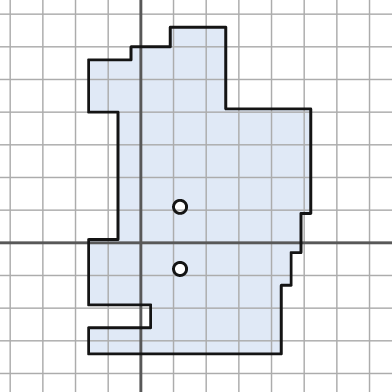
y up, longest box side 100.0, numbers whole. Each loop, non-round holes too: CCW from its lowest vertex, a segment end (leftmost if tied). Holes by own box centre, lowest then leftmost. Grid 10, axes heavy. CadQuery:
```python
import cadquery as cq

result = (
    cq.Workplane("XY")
    .moveTo(-16.0, -34.0)
    .lineTo(43.0, -34.0)
    .lineTo(43.0, -13.0)
    .lineTo(46.0, -13.0)
    .lineTo(46.0, -3.0)
    .lineTo(49.0, -3.0)
    .lineTo(49.0, 9.0)
    .lineTo(52.0, 9.0)
    .lineTo(52.0, 41.0)
    .lineTo(26.0, 41.0)
    .lineTo(26.0, 66.0)
    .lineTo(9.0, 66.0)
    .lineTo(9.0, 60.0)
    .lineTo(-3.0, 60.0)
    .lineTo(-3.0, 56.0)
    .lineTo(-16.0, 56.0)
    .lineTo(-16.0, 40.0)
    .lineTo(-7.0, 40.0)
    .lineTo(-7.0, 1.0)
    .lineTo(-16.0, 1.0)
    .lineTo(-16.0, -19.0)
    .lineTo(3.0, -19.0)
    .lineTo(3.0, -26.0)
    .lineTo(-16.0, -26.0)
    .close()
    .moveTo(12.0, -8.0)
    .circle(2.0)
    .moveTo(12.0, 11.0)
    .circle(2.0)
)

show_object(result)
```